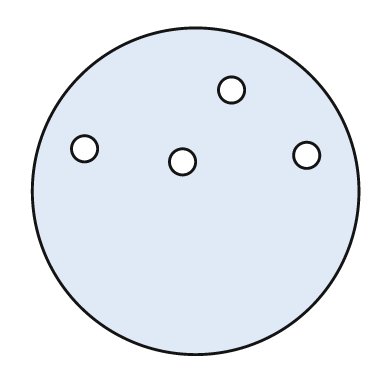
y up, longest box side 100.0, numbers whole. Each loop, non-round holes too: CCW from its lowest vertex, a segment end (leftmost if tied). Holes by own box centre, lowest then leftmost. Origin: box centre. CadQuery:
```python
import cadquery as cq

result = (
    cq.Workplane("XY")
    .moveTo(0.0, 0.0)
    .circle(50.0)
    .moveTo(-4.0, 9.0)
    .circle(4.0)
    .moveTo(34.0, 11.0)
    .circle(4.0)
    .moveTo(-34.0, 13.0)
    .circle(4.0)
    .moveTo(11.0, 31.0)
    .circle(4.0)
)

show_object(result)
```